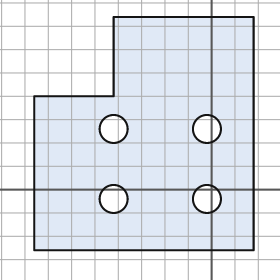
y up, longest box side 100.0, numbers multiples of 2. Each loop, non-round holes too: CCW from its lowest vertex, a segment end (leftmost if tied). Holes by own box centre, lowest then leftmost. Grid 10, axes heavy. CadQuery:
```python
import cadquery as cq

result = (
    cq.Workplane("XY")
    .moveTo(-76.0, -26.0)
    .lineTo(18.0, -26.0)
    .lineTo(18.0, 74.0)
    .lineTo(-42.0, 74.0)
    .lineTo(-42.0, 40.0)
    .lineTo(-76.0, 40.0)
    .close()
    .moveTo(-42.0, -4.0)
    .circle(6.0)
    .moveTo(-2.0, -4.0)
    .circle(6.0)
    .moveTo(-42.0, 26.0)
    .circle(6.0)
    .moveTo(-2.0, 26.0)
    .circle(6.0)
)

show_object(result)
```